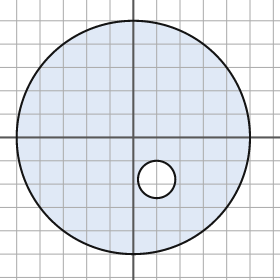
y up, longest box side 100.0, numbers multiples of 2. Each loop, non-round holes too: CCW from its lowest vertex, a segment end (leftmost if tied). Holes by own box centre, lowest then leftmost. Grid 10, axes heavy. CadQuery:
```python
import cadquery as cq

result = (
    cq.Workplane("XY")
    .moveTo(0.0, 0.0)
    .circle(50.0)
    .moveTo(10.0, -18.0)
    .circle(8.0)
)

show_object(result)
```